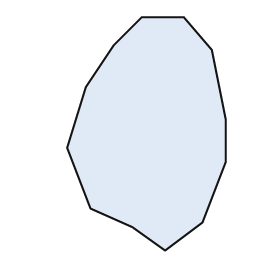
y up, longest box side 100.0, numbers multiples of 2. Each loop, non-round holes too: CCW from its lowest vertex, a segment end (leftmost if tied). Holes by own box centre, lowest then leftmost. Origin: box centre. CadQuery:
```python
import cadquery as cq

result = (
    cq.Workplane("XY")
    .moveTo(8.0, -50.0)
    .lineTo(24.0, -38.0)
    .lineTo(34.0, -12.0)
    .lineTo(34.0, 6.0)
    .lineTo(28.0, 36.0)
    .lineTo(16.0, 50.0)
    .lineTo(-2.0, 50.0)
    .lineTo(-14.0, 38.0)
    .lineTo(-26.0, 20.0)
    .lineTo(-34.0, -6.0)
    .lineTo(-24.0, -32.0)
    .lineTo(-6.0, -40.0)
    .close()
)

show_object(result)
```